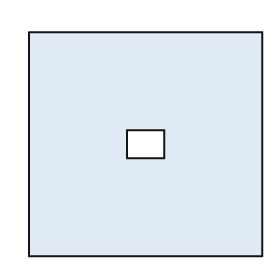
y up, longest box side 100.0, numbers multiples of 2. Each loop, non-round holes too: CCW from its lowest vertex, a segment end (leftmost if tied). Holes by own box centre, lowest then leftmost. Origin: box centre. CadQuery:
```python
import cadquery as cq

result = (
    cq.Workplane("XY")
    .moveTo(-50.0, -48.0)
    .lineTo(50.0, -48.0)
    .lineTo(50.0, 48.0)
    .lineTo(-50.0, 48.0)
    .close()
    .moveTo(-8.0, -6.0)
    .lineTo(8.0, -6.0)
    .lineTo(8.0, 6.0)
    .lineTo(-8.0, 6.0)
    .close()
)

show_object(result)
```